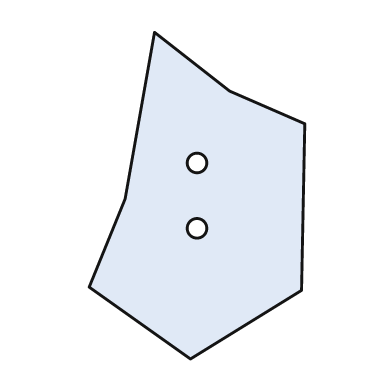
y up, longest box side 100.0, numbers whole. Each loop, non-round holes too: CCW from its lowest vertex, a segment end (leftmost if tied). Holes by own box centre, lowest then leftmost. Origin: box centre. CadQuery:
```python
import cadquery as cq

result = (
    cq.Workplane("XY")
    .moveTo(-2.0, -50.0)
    .lineTo(32.0, -29.0)
    .lineTo(33.0, 22.0)
    .lineTo(10.0, 32.0)
    .lineTo(-13.0, 50.0)
    .lineTo(-22.0, -1.0)
    .lineTo(-33.0, -28.0)
    .close()
    .moveTo(0.0, -10.0)
    .circle(3.0)
    .moveTo(0.0, 10.0)
    .circle(3.0)
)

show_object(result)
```